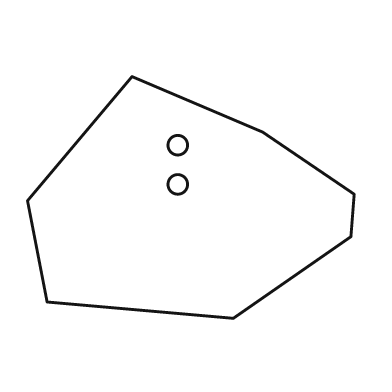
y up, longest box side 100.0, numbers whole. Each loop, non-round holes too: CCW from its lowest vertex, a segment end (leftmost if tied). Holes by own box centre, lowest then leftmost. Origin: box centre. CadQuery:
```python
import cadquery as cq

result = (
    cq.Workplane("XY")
    .moveTo(13.0, -37.0)
    .lineTo(49.0, -12.0)
    .lineTo(50.0, 1.0)
    .lineTo(22.0, 20.0)
    .lineTo(-18.0, 37.0)
    .lineTo(-50.0, -1.0)
    .lineTo(-44.0, -32.0)
    .close()
    .moveTo(-4.0, 4.0)
    .circle(3.0)
    .moveTo(-4.0, 16.0)
    .circle(3.0)
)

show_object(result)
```